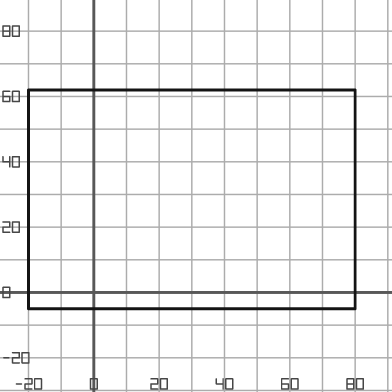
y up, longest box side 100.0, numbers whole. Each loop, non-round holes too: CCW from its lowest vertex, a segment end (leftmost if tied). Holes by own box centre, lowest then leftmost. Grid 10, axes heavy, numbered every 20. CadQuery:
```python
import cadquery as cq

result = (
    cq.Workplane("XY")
    .moveTo(-20.0, -5.0)
    .lineTo(80.0, -5.0)
    .lineTo(80.0, 62.0)
    .lineTo(-20.0, 62.0)
    .close()
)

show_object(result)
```